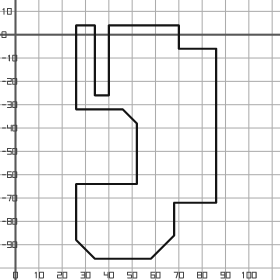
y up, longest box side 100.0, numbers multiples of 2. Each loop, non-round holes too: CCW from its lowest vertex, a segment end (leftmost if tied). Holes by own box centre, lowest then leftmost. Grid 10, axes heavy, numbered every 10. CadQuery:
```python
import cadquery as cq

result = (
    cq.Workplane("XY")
    .moveTo(34.0, -96.0)
    .lineTo(58.0, -96.0)
    .lineTo(68.0, -86.0)
    .lineTo(68.0, -72.0)
    .lineTo(86.0, -72.0)
    .lineTo(86.0, -6.0)
    .lineTo(70.0, -6.0)
    .lineTo(70.0, 4.0)
    .lineTo(40.0, 4.0)
    .lineTo(40.0, -26.0)
    .lineTo(34.0, -26.0)
    .lineTo(34.0, 4.0)
    .lineTo(26.0, 4.0)
    .lineTo(26.0, -32.0)
    .lineTo(46.0, -32.0)
    .lineTo(52.0, -38.0)
    .lineTo(52.0, -64.0)
    .lineTo(26.0, -64.0)
    .lineTo(26.0, -88.0)
    .close()
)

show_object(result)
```